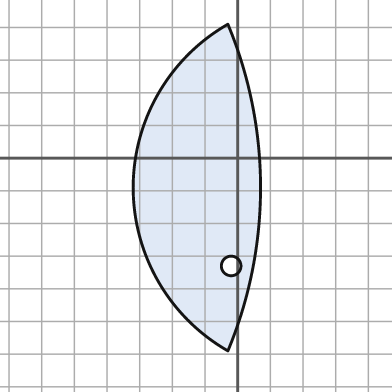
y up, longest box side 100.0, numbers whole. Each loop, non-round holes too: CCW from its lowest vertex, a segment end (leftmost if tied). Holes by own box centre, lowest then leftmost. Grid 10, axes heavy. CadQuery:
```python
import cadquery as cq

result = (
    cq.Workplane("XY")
    .moveTo(-3.0, -59.0)
    .threePointArc((7.0, -9.0), (-3.0, 41.0))
    .threePointArc((-32.0, -9.0), (-3.0, -59.0))
    .close()
    .moveTo(-2.0, -33.0)
    .circle(3.0)
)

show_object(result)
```